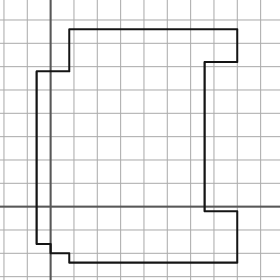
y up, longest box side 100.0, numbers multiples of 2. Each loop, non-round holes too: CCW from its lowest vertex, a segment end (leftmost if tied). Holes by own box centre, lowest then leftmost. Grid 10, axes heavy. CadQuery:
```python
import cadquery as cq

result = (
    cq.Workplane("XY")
    .moveTo(8.0, -24.0)
    .lineTo(80.0, -24.0)
    .lineTo(80.0, -2.0)
    .lineTo(66.0, -2.0)
    .lineTo(66.0, 62.0)
    .lineTo(80.0, 62.0)
    .lineTo(80.0, 76.0)
    .lineTo(8.0, 76.0)
    .lineTo(8.0, 58.0)
    .lineTo(-6.0, 58.0)
    .lineTo(-6.0, -16.0)
    .lineTo(0.0, -16.0)
    .lineTo(0.0, -20.0)
    .lineTo(8.0, -20.0)
    .close()
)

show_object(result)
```